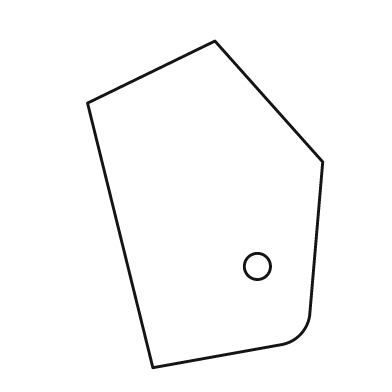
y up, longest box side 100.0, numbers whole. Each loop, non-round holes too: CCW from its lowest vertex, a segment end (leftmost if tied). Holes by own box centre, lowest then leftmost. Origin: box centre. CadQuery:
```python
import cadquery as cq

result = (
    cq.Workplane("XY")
    .moveTo(-16.0, -50.0)
    .lineTo(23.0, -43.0)
    .threePointArc((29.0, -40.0), (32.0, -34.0))
    .lineTo(36.0, 13.0)
    .lineTo(3.0, 50.0)
    .lineTo(-36.0, 31.0)
    .close()
    .moveTo(16.0, -19.0)
    .circle(4.0)
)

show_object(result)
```